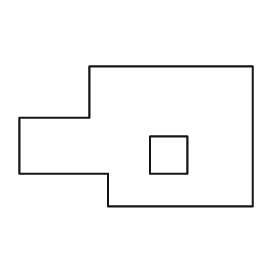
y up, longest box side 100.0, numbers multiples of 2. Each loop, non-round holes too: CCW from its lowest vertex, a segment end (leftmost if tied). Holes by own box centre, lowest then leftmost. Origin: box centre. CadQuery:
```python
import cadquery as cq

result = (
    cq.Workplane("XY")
    .moveTo(-12.0, -30.0)
    .lineTo(50.0, -30.0)
    .lineTo(50.0, 30.0)
    .lineTo(-20.0, 30.0)
    .lineTo(-20.0, 8.0)
    .lineTo(-50.0, 8.0)
    .lineTo(-50.0, -16.0)
    .lineTo(-12.0, -16.0)
    .close()
    .moveTo(6.0, -16.0)
    .lineTo(22.0, -16.0)
    .lineTo(22.0, 0.0)
    .lineTo(6.0, 0.0)
    .close()
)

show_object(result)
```